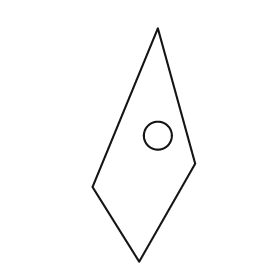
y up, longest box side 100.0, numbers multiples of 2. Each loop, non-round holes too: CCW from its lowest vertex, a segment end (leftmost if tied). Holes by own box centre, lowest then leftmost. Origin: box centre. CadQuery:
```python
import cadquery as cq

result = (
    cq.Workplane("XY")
    .moveTo(-2.0, -50.0)
    .lineTo(22.0, -8.0)
    .lineTo(6.0, 50.0)
    .lineTo(-22.0, -18.0)
    .close()
    .moveTo(6.0, 4.0)
    .circle(6.0)
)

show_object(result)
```